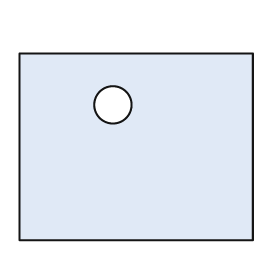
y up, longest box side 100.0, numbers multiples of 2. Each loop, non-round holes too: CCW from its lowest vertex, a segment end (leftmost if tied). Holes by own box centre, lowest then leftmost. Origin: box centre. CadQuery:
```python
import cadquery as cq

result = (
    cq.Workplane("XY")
    .moveTo(-50.0, -40.0)
    .lineTo(50.0, -40.0)
    .lineTo(50.0, 40.0)
    .lineTo(-50.0, 40.0)
    .close()
    .moveTo(-10.0, 18.0)
    .circle(8.0)
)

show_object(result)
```